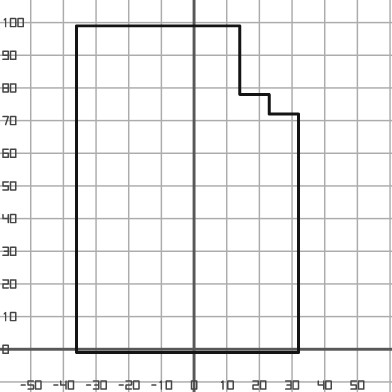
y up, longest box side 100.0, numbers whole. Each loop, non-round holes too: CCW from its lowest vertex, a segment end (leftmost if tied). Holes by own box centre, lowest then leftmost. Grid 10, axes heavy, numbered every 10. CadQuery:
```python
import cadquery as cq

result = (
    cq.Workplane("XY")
    .moveTo(-36.0, -1.0)
    .lineTo(32.0, -1.0)
    .lineTo(32.0, 72.0)
    .lineTo(23.0, 72.0)
    .lineTo(23.0, 78.0)
    .lineTo(14.0, 78.0)
    .lineTo(14.0, 99.0)
    .lineTo(-36.0, 99.0)
    .close()
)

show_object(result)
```